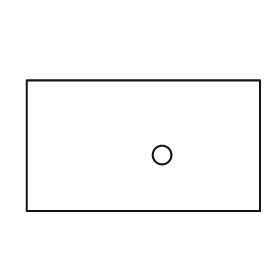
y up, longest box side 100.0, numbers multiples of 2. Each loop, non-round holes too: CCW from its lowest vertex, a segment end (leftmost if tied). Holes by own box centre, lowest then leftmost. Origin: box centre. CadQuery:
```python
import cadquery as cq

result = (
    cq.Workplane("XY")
    .moveTo(-50.0, -28.0)
    .lineTo(50.0, -28.0)
    .lineTo(50.0, 28.0)
    .lineTo(-50.0, 28.0)
    .close()
    .moveTo(8.0, -4.0)
    .circle(4.0)
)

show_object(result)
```